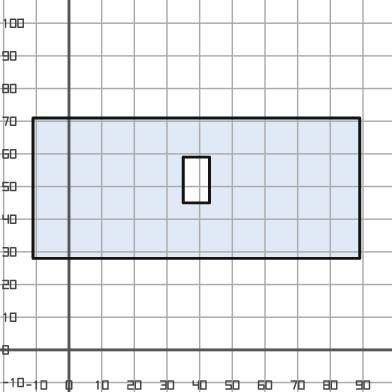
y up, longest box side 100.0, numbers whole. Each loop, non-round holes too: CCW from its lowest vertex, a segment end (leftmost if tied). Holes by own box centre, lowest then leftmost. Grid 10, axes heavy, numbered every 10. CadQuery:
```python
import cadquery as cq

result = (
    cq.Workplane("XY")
    .moveTo(-11.0, 28.0)
    .lineTo(89.0, 28.0)
    .lineTo(89.0, 71.0)
    .lineTo(-11.0, 71.0)
    .close()
    .moveTo(35.0, 45.0)
    .lineTo(43.0, 45.0)
    .lineTo(43.0, 59.0)
    .lineTo(35.0, 59.0)
    .close()
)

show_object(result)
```